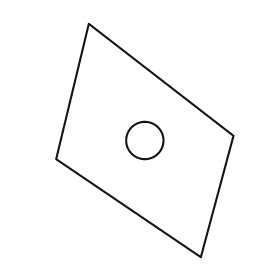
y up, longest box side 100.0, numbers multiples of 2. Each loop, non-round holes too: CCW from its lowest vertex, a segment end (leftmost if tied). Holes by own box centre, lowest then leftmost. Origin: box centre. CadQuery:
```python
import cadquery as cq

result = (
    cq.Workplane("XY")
    .moveTo(24.0, -50.0)
    .lineTo(38.0, 2.0)
    .lineTo(-24.0, 50.0)
    .lineTo(-38.0, -8.0)
    .close()
    .moveTo(0.0, 0.0)
    .circle(8.0)
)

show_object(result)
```